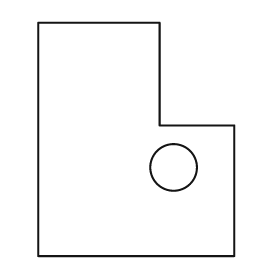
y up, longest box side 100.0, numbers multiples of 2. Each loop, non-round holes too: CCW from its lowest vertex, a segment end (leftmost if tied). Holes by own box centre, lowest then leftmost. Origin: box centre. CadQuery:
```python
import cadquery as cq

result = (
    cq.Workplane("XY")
    .moveTo(-42.0, -50.0)
    .lineTo(42.0, -50.0)
    .lineTo(42.0, 6.0)
    .lineTo(10.0, 6.0)
    .lineTo(10.0, 50.0)
    .lineTo(-42.0, 50.0)
    .close()
    .moveTo(16.0, -12.0)
    .circle(10.0)
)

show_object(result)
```